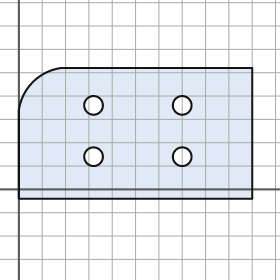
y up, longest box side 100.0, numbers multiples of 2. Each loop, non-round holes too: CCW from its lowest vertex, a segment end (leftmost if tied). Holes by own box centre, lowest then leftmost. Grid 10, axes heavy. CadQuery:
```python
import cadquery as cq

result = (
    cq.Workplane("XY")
    .moveTo(0.0, -4.0)
    .lineTo(100.0, -4.0)
    .lineTo(100.0, 52.0)
    .lineTo(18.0, 52.0)
    .threePointArc((6.0, 46.0), (0.0, 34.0))
    .close()
    .moveTo(32.0, 14.0)
    .circle(4.0)
    .moveTo(70.0, 14.0)
    .circle(4.0)
    .moveTo(32.0, 36.0)
    .circle(4.0)
    .moveTo(70.0, 36.0)
    .circle(4.0)
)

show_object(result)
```